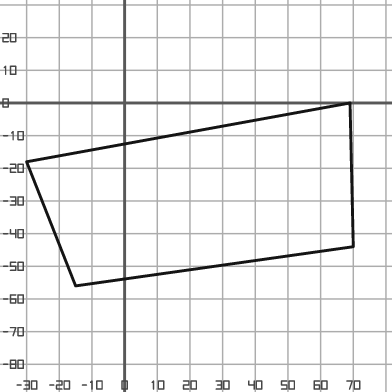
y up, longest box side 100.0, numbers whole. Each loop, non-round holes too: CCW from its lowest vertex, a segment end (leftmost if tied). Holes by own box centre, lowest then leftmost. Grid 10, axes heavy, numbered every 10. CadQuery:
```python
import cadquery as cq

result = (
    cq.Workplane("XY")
    .moveTo(-15.0, -56.0)
    .lineTo(70.0, -44.0)
    .lineTo(69.0, 0.0)
    .lineTo(-30.0, -18.0)
    .close()
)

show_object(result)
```